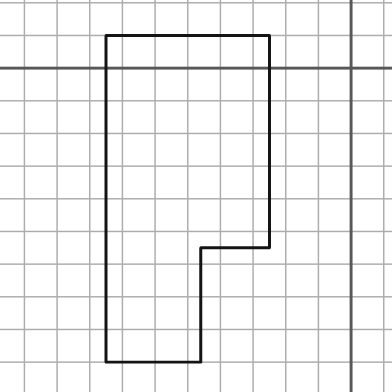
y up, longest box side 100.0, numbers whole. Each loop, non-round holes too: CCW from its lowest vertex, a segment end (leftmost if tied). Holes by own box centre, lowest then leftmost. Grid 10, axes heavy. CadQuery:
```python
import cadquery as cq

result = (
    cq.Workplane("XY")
    .moveTo(-75.0, -90.0)
    .lineTo(-46.0, -90.0)
    .lineTo(-46.0, -55.0)
    .lineTo(-25.0, -55.0)
    .lineTo(-25.0, 10.0)
    .lineTo(-75.0, 10.0)
    .close()
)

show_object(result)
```